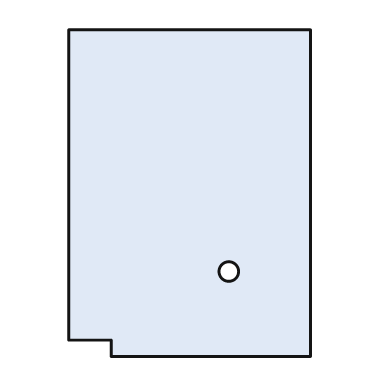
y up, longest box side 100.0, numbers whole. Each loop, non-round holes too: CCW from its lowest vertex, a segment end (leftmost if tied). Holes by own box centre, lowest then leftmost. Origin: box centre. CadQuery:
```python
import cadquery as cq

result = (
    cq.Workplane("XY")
    .moveTo(-24.0, -50.0)
    .lineTo(37.0, -50.0)
    .lineTo(37.0, 50.0)
    .lineTo(-37.0, 50.0)
    .lineTo(-37.0, -45.0)
    .lineTo(-24.0, -45.0)
    .close()
    .moveTo(12.0, -24.0)
    .circle(3.0)
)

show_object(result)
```